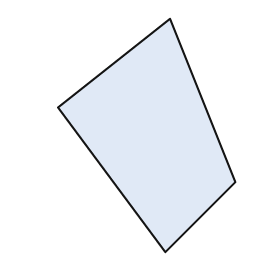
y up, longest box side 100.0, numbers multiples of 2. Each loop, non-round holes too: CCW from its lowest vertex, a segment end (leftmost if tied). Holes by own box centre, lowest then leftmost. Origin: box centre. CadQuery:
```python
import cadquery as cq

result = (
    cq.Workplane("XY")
    .moveTo(8.0, -50.0)
    .lineTo(38.0, -20.0)
    .lineTo(10.0, 50.0)
    .lineTo(-38.0, 12.0)
    .close()
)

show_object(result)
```